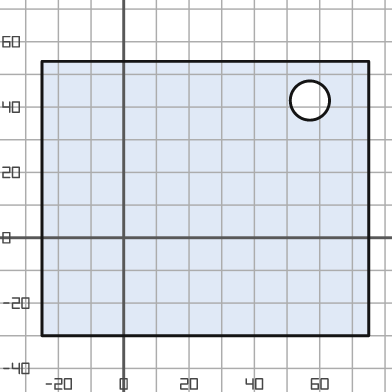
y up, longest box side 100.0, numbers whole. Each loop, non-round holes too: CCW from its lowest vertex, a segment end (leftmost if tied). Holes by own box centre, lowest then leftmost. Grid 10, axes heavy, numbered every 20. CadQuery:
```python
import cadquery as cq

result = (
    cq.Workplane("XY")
    .moveTo(-25.0, -30.0)
    .lineTo(75.0, -30.0)
    .lineTo(75.0, 54.0)
    .lineTo(-25.0, 54.0)
    .close()
    .moveTo(57.0, 42.0)
    .circle(6.0)
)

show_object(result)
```